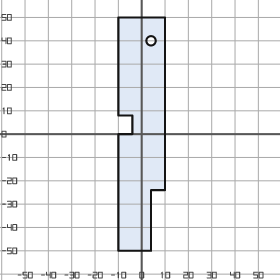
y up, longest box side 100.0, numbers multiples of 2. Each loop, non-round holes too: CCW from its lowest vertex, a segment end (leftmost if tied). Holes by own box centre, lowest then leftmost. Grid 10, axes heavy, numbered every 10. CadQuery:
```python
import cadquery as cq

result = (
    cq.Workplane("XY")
    .moveTo(-10.0, -50.0)
    .lineTo(4.0, -50.0)
    .lineTo(4.0, -24.0)
    .lineTo(10.0, -24.0)
    .lineTo(10.0, 50.0)
    .lineTo(-10.0, 50.0)
    .lineTo(-10.0, 8.0)
    .lineTo(-4.0, 8.0)
    .lineTo(-4.0, 0.0)
    .lineTo(-10.0, 0.0)
    .close()
    .moveTo(4.0, 40.0)
    .circle(2.0)
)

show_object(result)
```